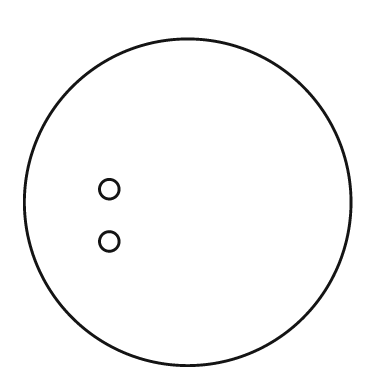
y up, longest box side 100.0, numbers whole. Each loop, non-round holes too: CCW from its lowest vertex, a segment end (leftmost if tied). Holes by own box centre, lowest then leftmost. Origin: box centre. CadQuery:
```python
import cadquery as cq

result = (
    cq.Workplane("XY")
    .moveTo(0.0, 0.0)
    .circle(50.0)
    .moveTo(-24.0, -12.0)
    .circle(3.0)
    .moveTo(-24.0, 4.0)
    .circle(3.0)
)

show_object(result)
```